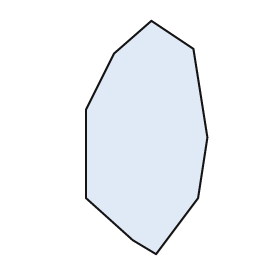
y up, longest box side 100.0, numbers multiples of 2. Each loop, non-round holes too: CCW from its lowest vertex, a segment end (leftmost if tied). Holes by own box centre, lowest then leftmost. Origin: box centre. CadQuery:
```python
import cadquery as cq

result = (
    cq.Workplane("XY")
    .moveTo(4.0, -50.0)
    .lineTo(22.0, -26.0)
    .lineTo(26.0, 0.0)
    .lineTo(20.0, 38.0)
    .lineTo(2.0, 50.0)
    .lineTo(-14.0, 36.0)
    .lineTo(-26.0, 12.0)
    .lineTo(-26.0, -26.0)
    .lineTo(-6.0, -44.0)
    .close()
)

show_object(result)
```